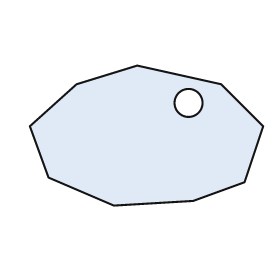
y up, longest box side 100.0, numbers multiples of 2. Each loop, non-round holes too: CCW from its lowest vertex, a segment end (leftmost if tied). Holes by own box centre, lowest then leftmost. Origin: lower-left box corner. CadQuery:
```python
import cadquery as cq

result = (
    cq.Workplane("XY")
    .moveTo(36.0, 0.0)
    .lineTo(70.0, 2.0)
    .lineTo(92.0, 10.0)
    .lineTo(100.0, 34.0)
    .lineTo(82.0, 52.0)
    .lineTo(46.0, 60.0)
    .lineTo(20.0, 52.0)
    .lineTo(0.0, 34.0)
    .lineTo(8.0, 12.0)
    .close()
    .moveTo(68.0, 44.0)
    .circle(6.0)
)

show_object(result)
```